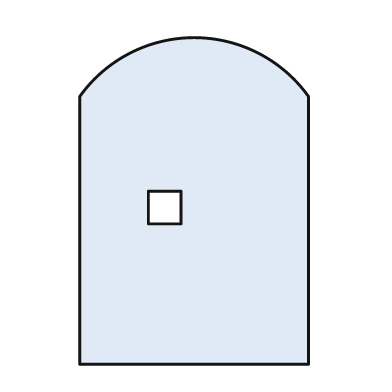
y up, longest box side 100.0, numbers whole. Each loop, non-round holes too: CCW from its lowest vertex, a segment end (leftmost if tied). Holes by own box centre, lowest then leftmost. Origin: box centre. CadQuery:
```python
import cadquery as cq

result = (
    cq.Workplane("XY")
    .moveTo(-35.0, -50.0)
    .lineTo(35.0, -50.0)
    .lineTo(35.0, 32.0)
    .threePointArc((0.0, 50.0), (-35.0, 32.0))
    .close()
    .moveTo(-14.0, -7.0)
    .lineTo(-4.0, -7.0)
    .lineTo(-4.0, 3.0)
    .lineTo(-14.0, 3.0)
    .close()
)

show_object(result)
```